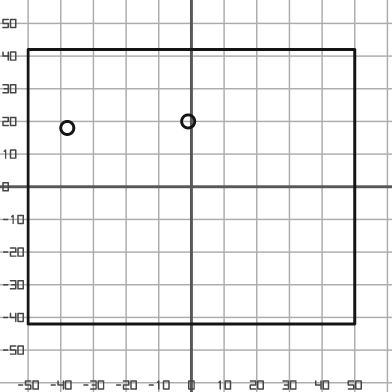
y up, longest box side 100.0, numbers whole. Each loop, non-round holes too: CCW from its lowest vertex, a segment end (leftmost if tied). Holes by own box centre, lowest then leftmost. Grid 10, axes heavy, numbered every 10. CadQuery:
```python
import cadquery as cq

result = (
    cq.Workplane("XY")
    .moveTo(-50.0, -42.0)
    .lineTo(50.0, -42.0)
    .lineTo(50.0, 42.0)
    .lineTo(-50.0, 42.0)
    .close()
    .moveTo(-38.0, 18.0)
    .circle(2.0)
    .moveTo(-1.0, 20.0)
    .circle(2.0)
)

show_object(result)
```